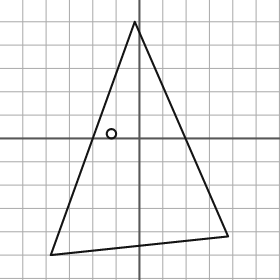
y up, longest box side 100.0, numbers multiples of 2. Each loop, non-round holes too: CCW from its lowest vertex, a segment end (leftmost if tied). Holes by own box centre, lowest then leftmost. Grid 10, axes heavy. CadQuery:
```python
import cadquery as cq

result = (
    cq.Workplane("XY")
    .moveTo(-38.0, -50.0)
    .lineTo(38.0, -42.0)
    .lineTo(-2.0, 50.0)
    .close()
    .moveTo(-12.0, 2.0)
    .circle(2.0)
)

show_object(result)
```